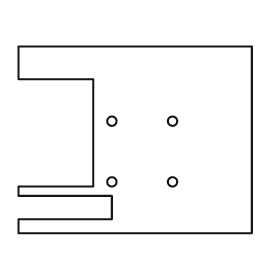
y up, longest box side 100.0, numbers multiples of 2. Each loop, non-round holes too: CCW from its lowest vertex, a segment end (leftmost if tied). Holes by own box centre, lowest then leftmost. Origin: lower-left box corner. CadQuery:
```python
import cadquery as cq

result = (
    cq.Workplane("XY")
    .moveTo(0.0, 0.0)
    .lineTo(100.0, 0.0)
    .lineTo(100.0, 80.0)
    .lineTo(0.0, 80.0)
    .lineTo(0.0, 66.0)
    .lineTo(32.0, 66.0)
    .lineTo(32.0, 20.0)
    .lineTo(0.0, 20.0)
    .lineTo(0.0, 16.0)
    .lineTo(40.0, 16.0)
    .lineTo(40.0, 6.0)
    .lineTo(0.0, 6.0)
    .close()
    .moveTo(40.0, 22.0)
    .circle(2.0)
    .moveTo(66.0, 22.0)
    .circle(2.0)
    .moveTo(40.0, 48.0)
    .circle(2.0)
    .moveTo(66.0, 48.0)
    .circle(2.0)
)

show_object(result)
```